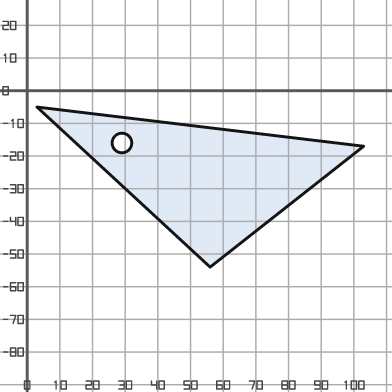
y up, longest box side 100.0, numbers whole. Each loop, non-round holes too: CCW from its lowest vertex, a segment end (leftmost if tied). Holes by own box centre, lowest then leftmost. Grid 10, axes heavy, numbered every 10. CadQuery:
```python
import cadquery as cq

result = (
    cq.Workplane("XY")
    .moveTo(56.0, -54.0)
    .lineTo(103.0, -17.0)
    .lineTo(3.0, -5.0)
    .close()
    .moveTo(29.0, -16.0)
    .circle(3.0)
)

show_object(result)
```